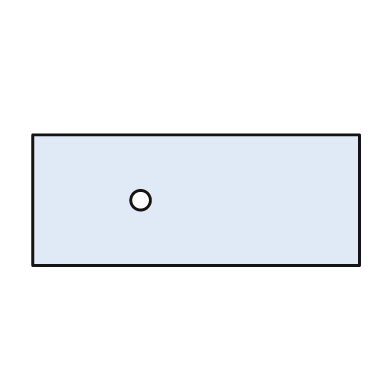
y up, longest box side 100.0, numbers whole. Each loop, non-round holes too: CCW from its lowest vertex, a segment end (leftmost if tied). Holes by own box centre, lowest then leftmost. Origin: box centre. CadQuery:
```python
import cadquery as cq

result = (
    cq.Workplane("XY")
    .moveTo(-50.0, -20.0)
    .lineTo(50.0, -20.0)
    .lineTo(50.0, 20.0)
    .lineTo(-50.0, 20.0)
    .close()
    .moveTo(-17.0, 0.0)
    .circle(3.0)
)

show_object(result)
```